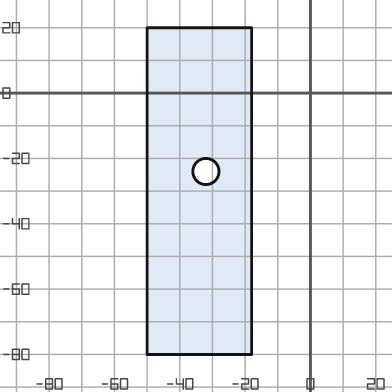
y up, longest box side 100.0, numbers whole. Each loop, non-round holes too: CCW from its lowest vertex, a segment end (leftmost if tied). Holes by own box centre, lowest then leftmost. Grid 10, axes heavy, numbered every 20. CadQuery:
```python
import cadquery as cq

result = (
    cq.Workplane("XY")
    .moveTo(-50.0, -80.0)
    .lineTo(-18.0, -80.0)
    .lineTo(-18.0, 20.0)
    .lineTo(-50.0, 20.0)
    .close()
    .moveTo(-32.0, -24.0)
    .circle(4.0)
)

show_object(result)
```